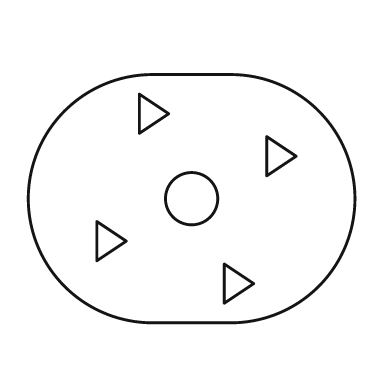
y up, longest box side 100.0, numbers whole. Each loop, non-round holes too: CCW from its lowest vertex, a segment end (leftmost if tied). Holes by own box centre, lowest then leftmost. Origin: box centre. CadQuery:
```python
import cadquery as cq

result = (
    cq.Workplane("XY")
    .moveTo(-12.0, -38.0)
    .lineTo(12.0, -38.0)
    .threePointArc((50.0, 0.0), (12.0, 38.0))
    .lineTo(-12.0, 38.0)
    .threePointArc((-50.0, 0.0), (-12.0, -38.0))
    .close()
    .moveTo(10.0, -32.0)
    .lineTo(19.0, -26.0)
    .lineTo(10.0, -20.0)
    .close()
    .moveTo(-29.0, -19.0)
    .lineTo(-20.0, -13.0)
    .lineTo(-29.0, -7.0)
    .close()
    .moveTo(0.0, 0.0)
    .circle(8.0)
    .moveTo(23.0, 7.0)
    .lineTo(32.0, 13.0)
    .lineTo(23.0, 19.0)
    .close()
    .moveTo(-16.0, 20.0)
    .lineTo(-7.0, 26.0)
    .lineTo(-16.0, 32.0)
    .close()
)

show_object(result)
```